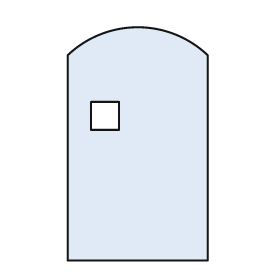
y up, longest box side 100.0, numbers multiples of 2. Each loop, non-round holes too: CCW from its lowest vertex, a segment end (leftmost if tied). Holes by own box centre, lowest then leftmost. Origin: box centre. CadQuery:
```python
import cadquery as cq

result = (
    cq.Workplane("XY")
    .moveTo(-30.0, -50.0)
    .lineTo(30.0, -50.0)
    .lineTo(30.0, 38.0)
    .threePointArc((0.0, 50.0), (-30.0, 38.0))
    .close()
    .moveTo(-20.0, 6.0)
    .lineTo(-8.0, 6.0)
    .lineTo(-8.0, 18.0)
    .lineTo(-20.0, 18.0)
    .close()
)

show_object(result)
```